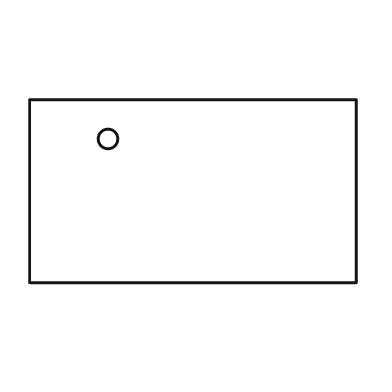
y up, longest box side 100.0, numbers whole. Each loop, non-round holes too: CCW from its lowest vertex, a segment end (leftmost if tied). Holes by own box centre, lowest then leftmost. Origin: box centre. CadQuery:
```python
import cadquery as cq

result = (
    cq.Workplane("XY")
    .moveTo(-50.0, -28.0)
    .lineTo(50.0, -28.0)
    .lineTo(50.0, 28.0)
    .lineTo(-50.0, 28.0)
    .close()
    .moveTo(-26.0, 16.0)
    .circle(3.0)
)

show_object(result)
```